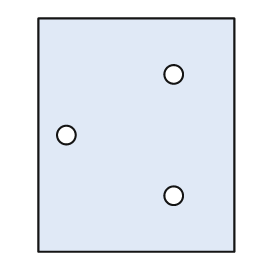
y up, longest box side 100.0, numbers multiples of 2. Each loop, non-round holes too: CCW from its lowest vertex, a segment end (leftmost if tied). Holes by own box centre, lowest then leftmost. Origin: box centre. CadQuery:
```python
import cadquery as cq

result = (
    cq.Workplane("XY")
    .moveTo(-42.0, -50.0)
    .lineTo(42.0, -50.0)
    .lineTo(42.0, 50.0)
    .lineTo(-42.0, 50.0)
    .close()
    .moveTo(16.0, -26.0)
    .circle(4.0)
    .moveTo(-30.0, 0.0)
    .circle(4.0)
    .moveTo(16.0, 26.0)
    .circle(4.0)
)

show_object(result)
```